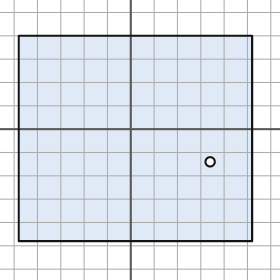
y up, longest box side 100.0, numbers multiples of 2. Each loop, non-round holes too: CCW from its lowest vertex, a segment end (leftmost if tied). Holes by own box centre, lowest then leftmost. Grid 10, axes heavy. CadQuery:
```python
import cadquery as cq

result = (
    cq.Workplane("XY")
    .moveTo(-48.0, -48.0)
    .lineTo(52.0, -48.0)
    .lineTo(52.0, 40.0)
    .lineTo(-48.0, 40.0)
    .close()
    .moveTo(34.0, -14.0)
    .circle(2.0)
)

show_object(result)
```